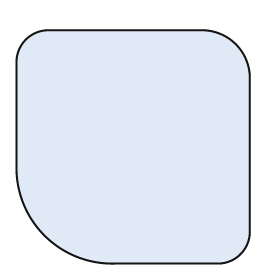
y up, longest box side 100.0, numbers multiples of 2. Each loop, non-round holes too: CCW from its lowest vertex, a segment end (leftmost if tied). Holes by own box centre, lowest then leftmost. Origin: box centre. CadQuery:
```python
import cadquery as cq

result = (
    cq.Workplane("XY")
    .moveTo(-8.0, -50.0)
    .lineTo(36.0, -50.0)
    .threePointArc((46.0, -46.0), (50.0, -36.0))
    .lineTo(50.0, 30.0)
    .threePointArc((44.0, 44.0), (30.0, 50.0))
    .lineTo(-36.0, 50.0)
    .threePointArc((-46.0, 46.0), (-50.0, 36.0))
    .lineTo(-50.0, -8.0)
    .threePointArc((-38.0, -38.0), (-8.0, -50.0))
    .close()
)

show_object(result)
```